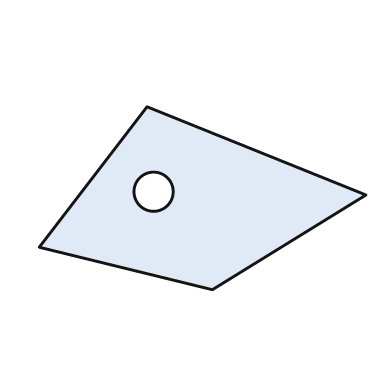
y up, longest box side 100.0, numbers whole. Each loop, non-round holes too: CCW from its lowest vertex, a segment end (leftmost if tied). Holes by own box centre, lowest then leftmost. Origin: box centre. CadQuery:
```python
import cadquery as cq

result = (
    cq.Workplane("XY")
    .moveTo(3.0, -28.0)
    .lineTo(50.0, 1.0)
    .lineTo(-17.0, 28.0)
    .lineTo(-50.0, -15.0)
    .close()
    .moveTo(-15.0, 2.0)
    .circle(6.0)
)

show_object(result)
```